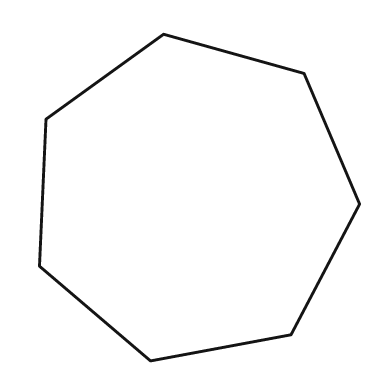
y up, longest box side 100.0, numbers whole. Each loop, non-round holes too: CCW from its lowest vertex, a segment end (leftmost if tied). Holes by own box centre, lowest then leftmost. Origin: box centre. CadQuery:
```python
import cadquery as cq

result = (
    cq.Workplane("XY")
    .moveTo(-15.0, -50.0)
    .lineTo(28.0, -42.0)
    .lineTo(49.0, -2.0)
    .lineTo(32.0, 38.0)
    .lineTo(-11.0, 50.0)
    .lineTo(-47.0, 24.0)
    .lineTo(-49.0, -21.0)
    .close()
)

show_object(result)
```